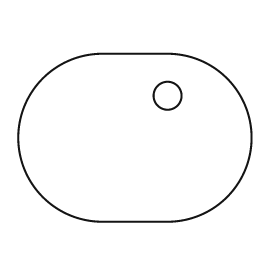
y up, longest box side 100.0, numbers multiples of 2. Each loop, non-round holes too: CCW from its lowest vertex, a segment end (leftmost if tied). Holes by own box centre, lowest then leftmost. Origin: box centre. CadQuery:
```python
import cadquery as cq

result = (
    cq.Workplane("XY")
    .moveTo(-14.0, -36.0)
    .lineTo(14.0, -36.0)
    .threePointArc((50.0, 0.0), (14.0, 36.0))
    .lineTo(-14.0, 36.0)
    .threePointArc((-50.0, 0.0), (-14.0, -36.0))
    .close()
    .moveTo(14.0, 18.0)
    .circle(6.0)
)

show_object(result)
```